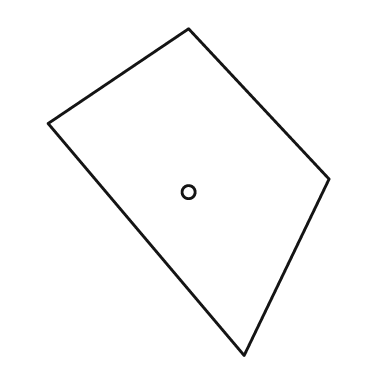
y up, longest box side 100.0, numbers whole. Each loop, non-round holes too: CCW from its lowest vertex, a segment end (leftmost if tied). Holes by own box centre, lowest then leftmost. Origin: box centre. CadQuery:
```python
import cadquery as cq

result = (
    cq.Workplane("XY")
    .moveTo(17.0, -50.0)
    .lineTo(43.0, 4.0)
    .lineTo(0.0, 50.0)
    .lineTo(-43.0, 21.0)
    .close()
    .moveTo(0.0, 0.0)
    .circle(2.0)
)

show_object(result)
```